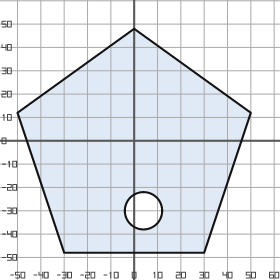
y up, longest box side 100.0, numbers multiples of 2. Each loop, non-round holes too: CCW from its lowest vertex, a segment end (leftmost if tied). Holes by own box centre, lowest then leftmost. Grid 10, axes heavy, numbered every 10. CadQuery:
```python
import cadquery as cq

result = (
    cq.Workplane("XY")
    .moveTo(-30.0, -48.0)
    .lineTo(30.0, -48.0)
    .lineTo(50.0, 12.0)
    .lineTo(0.0, 48.0)
    .lineTo(-50.0, 12.0)
    .close()
    .moveTo(4.0, -30.0)
    .circle(8.0)
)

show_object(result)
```